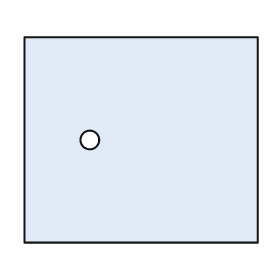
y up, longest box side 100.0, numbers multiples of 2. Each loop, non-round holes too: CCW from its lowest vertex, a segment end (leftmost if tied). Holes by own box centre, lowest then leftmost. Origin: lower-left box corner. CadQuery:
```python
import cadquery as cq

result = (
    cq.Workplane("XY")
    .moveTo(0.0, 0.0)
    .lineTo(100.0, 0.0)
    .lineTo(100.0, 88.0)
    .lineTo(0.0, 88.0)
    .close()
    .moveTo(28.0, 44.0)
    .circle(4.0)
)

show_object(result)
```